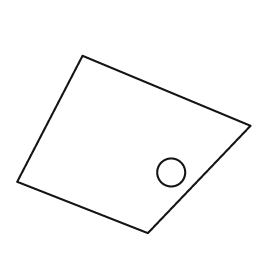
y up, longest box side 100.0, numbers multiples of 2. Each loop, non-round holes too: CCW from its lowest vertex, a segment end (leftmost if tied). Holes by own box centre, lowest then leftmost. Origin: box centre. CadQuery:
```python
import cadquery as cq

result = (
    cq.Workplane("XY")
    .moveTo(6.0, -38.0)
    .lineTo(50.0, 8.0)
    .lineTo(-22.0, 38.0)
    .lineTo(-50.0, -16.0)
    .close()
    .moveTo(16.0, -12.0)
    .circle(6.0)
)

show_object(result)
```